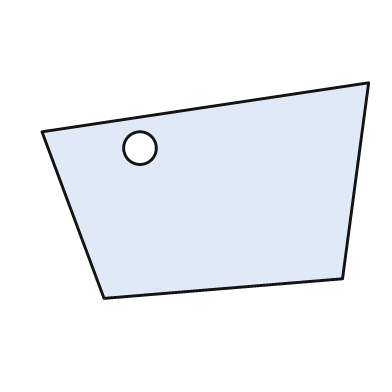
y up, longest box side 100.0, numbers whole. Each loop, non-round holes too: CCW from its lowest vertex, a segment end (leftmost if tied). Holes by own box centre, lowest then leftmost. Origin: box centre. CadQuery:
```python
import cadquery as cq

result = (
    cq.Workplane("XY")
    .moveTo(-31.0, -33.0)
    .lineTo(42.0, -27.0)
    .lineTo(50.0, 33.0)
    .lineTo(-50.0, 18.0)
    .close()
    .moveTo(-20.0, 13.0)
    .circle(5.0)
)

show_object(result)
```